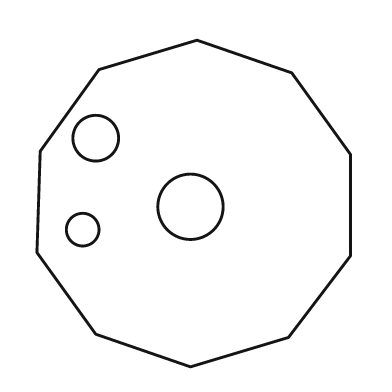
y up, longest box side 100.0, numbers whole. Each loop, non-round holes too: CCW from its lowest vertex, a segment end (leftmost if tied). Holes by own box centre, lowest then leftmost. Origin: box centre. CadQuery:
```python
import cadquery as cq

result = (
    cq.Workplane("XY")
    .moveTo(-1.0, -50.0)
    .lineTo(29.0, -41.0)
    .lineTo(48.0, -16.0)
    .lineTo(48.0, 15.0)
    .lineTo(30.0, 40.0)
    .lineTo(1.0, 50.0)
    .lineTo(-29.0, 41.0)
    .lineTo(-47.0, 16.0)
    .lineTo(-48.0, -15.0)
    .lineTo(-30.0, -40.0)
    .close()
    .moveTo(-34.0, -8.0)
    .circle(5.0)
    .moveTo(-1.0, -1.0)
    .circle(10.0)
    .moveTo(-30.0, 20.0)
    .circle(7.0)
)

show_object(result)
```